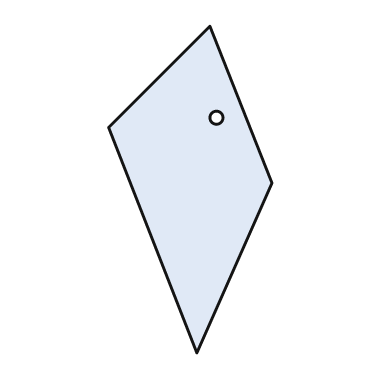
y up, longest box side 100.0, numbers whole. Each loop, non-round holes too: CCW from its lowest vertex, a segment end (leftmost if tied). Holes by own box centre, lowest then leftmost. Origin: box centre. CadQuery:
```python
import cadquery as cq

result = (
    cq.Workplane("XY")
    .moveTo(2.0, -50.0)
    .lineTo(25.0, 2.0)
    .lineTo(6.0, 50.0)
    .lineTo(-25.0, 19.0)
    .close()
    .moveTo(8.0, 22.0)
    .circle(2.0)
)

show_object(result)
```